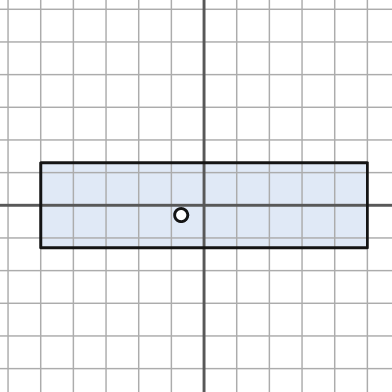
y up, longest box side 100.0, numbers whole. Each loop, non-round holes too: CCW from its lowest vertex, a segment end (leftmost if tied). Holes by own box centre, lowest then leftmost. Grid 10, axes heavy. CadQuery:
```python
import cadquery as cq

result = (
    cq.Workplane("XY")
    .moveTo(-50.0, -13.0)
    .lineTo(50.0, -13.0)
    .lineTo(50.0, 13.0)
    .lineTo(-50.0, 13.0)
    .close()
    .moveTo(-7.0, -3.0)
    .circle(2.0)
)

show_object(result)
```